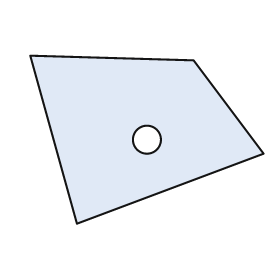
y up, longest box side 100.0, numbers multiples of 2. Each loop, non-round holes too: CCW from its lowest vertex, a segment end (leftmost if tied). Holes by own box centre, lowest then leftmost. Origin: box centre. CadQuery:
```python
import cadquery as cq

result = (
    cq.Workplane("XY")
    .moveTo(-30.0, -36.0)
    .lineTo(50.0, -6.0)
    .lineTo(20.0, 34.0)
    .lineTo(-50.0, 36.0)
    .close()
    .moveTo(0.0, 0.0)
    .circle(6.0)
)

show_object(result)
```